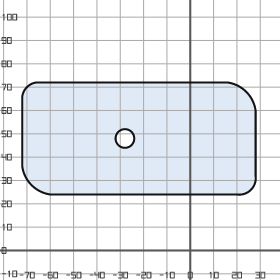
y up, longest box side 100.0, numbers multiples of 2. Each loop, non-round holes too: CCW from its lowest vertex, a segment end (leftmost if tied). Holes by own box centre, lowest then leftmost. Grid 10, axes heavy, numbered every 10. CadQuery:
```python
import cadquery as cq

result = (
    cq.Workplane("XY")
    .moveTo(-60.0, 24.0)
    .lineTo(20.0, 24.0)
    .threePointArc((26.0, 26.0), (28.0, 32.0))
    .lineTo(28.0, 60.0)
    .threePointArc((24.0, 68.0), (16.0, 72.0))
    .lineTo(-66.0, 72.0)
    .threePointArc((-70.0, 70.0), (-72.0, 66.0))
    .lineTo(-72.0, 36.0)
    .threePointArc((-68.0, 28.0), (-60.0, 24.0))
    .close()
    .moveTo(-28.0, 48.0)
    .circle(4.0)
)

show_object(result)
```